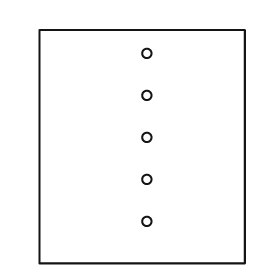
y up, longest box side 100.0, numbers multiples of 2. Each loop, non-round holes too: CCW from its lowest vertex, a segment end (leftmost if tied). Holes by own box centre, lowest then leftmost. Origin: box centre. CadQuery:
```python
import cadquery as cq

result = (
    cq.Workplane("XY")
    .moveTo(-44.0, -50.0)
    .lineTo(44.0, -50.0)
    .lineTo(44.0, 50.0)
    .lineTo(-44.0, 50.0)
    .close()
    .moveTo(2.0, -32.0)
    .circle(2.0)
    .moveTo(2.0, -14.0)
    .circle(2.0)
    .moveTo(2.0, 4.0)
    .circle(2.0)
    .moveTo(2.0, 22.0)
    .circle(2.0)
    .moveTo(2.0, 40.0)
    .circle(2.0)
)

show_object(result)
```